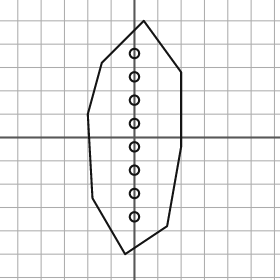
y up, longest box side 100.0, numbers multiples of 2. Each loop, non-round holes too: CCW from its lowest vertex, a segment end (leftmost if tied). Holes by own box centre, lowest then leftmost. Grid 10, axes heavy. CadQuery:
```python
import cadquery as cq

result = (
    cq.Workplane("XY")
    .moveTo(-4.0, -50.0)
    .lineTo(14.0, -38.0)
    .lineTo(20.0, -4.0)
    .lineTo(20.0, 28.0)
    .lineTo(4.0, 50.0)
    .lineTo(-14.0, 32.0)
    .lineTo(-20.0, 10.0)
    .lineTo(-18.0, -26.0)
    .close()
    .moveTo(0.0, -34.0)
    .circle(2.0)
    .moveTo(0.0, -24.0)
    .circle(2.0)
    .moveTo(0.0, -14.0)
    .circle(2.0)
    .moveTo(0.0, -4.0)
    .circle(2.0)
    .moveTo(0.0, 6.0)
    .circle(2.0)
    .moveTo(0.0, 16.0)
    .circle(2.0)
    .moveTo(0.0, 26.0)
    .circle(2.0)
    .moveTo(0.0, 36.0)
    .circle(2.0)
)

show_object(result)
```